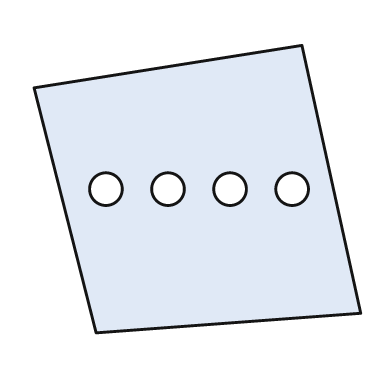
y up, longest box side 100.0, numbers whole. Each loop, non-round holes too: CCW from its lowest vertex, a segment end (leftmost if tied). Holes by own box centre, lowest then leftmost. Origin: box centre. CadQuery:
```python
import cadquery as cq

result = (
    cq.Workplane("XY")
    .moveTo(-31.0, -44.0)
    .lineTo(50.0, -38.0)
    .lineTo(32.0, 44.0)
    .lineTo(-50.0, 31.0)
    .close()
    .moveTo(-28.0, 0.0)
    .circle(5.0)
    .moveTo(-9.0, 0.0)
    .circle(5.0)
    .moveTo(10.0, 0.0)
    .circle(5.0)
    .moveTo(29.0, 0.0)
    .circle(5.0)
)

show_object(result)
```